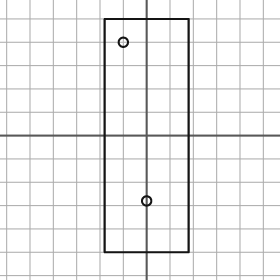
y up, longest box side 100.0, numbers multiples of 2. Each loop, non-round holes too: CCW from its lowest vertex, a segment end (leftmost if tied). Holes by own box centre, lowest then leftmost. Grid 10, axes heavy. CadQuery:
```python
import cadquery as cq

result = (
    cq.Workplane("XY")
    .moveTo(-18.0, -50.0)
    .lineTo(18.0, -50.0)
    .lineTo(18.0, 50.0)
    .lineTo(-18.0, 50.0)
    .close()
    .moveTo(0.0, -28.0)
    .circle(2.0)
    .moveTo(-10.0, 40.0)
    .circle(2.0)
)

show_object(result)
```